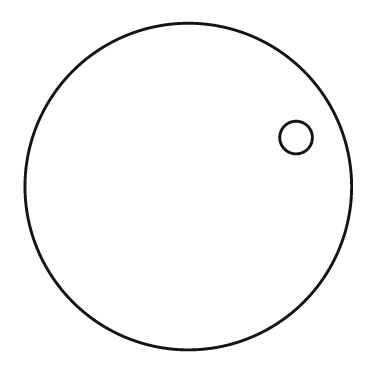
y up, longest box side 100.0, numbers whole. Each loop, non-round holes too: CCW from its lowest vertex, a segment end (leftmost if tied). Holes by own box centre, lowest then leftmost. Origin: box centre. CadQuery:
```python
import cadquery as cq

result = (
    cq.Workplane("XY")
    .moveTo(0.0, 0.0)
    .circle(50.0)
    .moveTo(33.0, 15.0)
    .circle(5.0)
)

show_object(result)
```